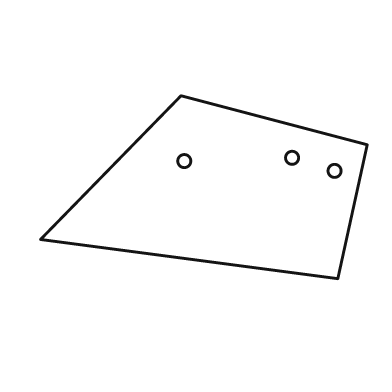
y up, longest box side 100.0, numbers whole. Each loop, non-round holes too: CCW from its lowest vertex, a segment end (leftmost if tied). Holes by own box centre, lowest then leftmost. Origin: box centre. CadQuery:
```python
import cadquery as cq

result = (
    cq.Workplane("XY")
    .moveTo(41.0, -28.0)
    .lineTo(50.0, 13.0)
    .lineTo(-7.0, 28.0)
    .lineTo(-50.0, -16.0)
    .close()
    .moveTo(40.0, 5.0)
    .circle(2.0)
    .moveTo(-6.0, 8.0)
    .circle(2.0)
    .moveTo(27.0, 9.0)
    .circle(2.0)
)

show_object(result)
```